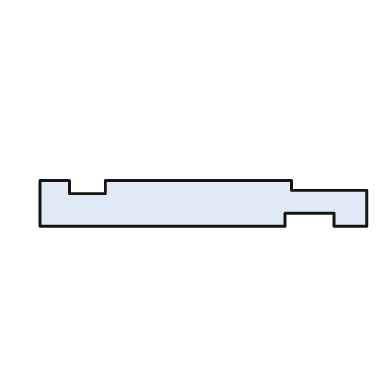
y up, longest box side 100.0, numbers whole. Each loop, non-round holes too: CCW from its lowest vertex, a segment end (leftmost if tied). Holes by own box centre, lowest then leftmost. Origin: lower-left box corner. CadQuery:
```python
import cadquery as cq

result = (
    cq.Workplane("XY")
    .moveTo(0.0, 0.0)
    .lineTo(75.0, 0.0)
    .lineTo(75.0, 4.0)
    .lineTo(90.0, 4.0)
    .lineTo(90.0, 0.0)
    .lineTo(100.0, 0.0)
    .lineTo(100.0, 11.0)
    .lineTo(77.0, 11.0)
    .lineTo(77.0, 14.0)
    .lineTo(20.0, 14.0)
    .lineTo(20.0, 10.0)
    .lineTo(9.0, 10.0)
    .lineTo(9.0, 14.0)
    .lineTo(0.0, 14.0)
    .close()
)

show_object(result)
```